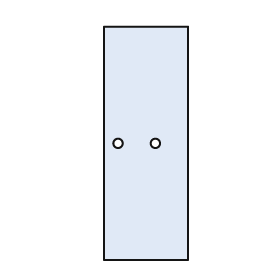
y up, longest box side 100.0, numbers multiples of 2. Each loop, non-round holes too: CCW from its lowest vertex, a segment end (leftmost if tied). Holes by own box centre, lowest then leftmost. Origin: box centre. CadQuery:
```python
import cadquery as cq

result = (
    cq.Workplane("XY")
    .moveTo(-18.0, -50.0)
    .lineTo(18.0, -50.0)
    .lineTo(18.0, 50.0)
    .lineTo(-18.0, 50.0)
    .close()
    .moveTo(-12.0, 0.0)
    .circle(2.0)
    .moveTo(4.0, 0.0)
    .circle(2.0)
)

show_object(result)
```